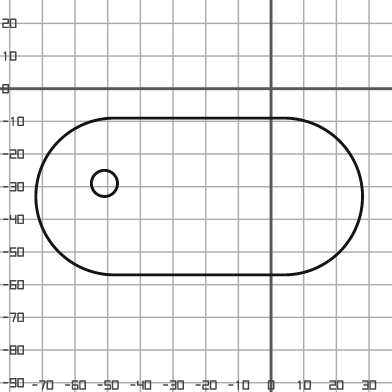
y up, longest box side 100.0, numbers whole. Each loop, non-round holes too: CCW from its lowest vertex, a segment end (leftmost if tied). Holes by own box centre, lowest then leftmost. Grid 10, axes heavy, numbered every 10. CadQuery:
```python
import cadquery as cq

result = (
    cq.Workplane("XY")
    .moveTo(-48.0, -57.0)
    .lineTo(4.0, -57.0)
    .threePointArc((28.0, -33.0), (4.0, -9.0))
    .lineTo(-48.0, -9.0)
    .threePointArc((-72.0, -33.0), (-48.0, -57.0))
    .close()
    .moveTo(-51.0, -29.0)
    .circle(4.0)
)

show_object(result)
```